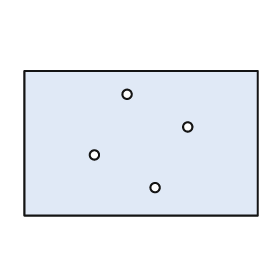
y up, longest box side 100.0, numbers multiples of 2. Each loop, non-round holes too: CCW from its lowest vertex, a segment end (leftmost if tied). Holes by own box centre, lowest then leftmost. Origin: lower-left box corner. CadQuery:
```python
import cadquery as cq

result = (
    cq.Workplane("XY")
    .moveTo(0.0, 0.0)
    .lineTo(100.0, 0.0)
    .lineTo(100.0, 62.0)
    .lineTo(0.0, 62.0)
    .close()
    .moveTo(56.0, 12.0)
    .circle(2.0)
    .moveTo(30.0, 26.0)
    .circle(2.0)
    .moveTo(70.0, 38.0)
    .circle(2.0)
    .moveTo(44.0, 52.0)
    .circle(2.0)
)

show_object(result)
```